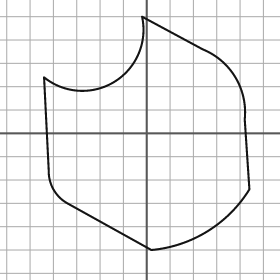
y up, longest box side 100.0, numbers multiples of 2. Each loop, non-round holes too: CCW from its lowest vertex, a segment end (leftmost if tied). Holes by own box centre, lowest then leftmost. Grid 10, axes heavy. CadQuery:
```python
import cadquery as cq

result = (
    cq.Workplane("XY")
    .moveTo(2.0, -50.0)
    .threePointArc((26.0, -42.0), (44.0, -24.0))
    .lineTo(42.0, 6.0)
    .threePointArc((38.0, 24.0), (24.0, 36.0))
    .lineTo(-2.0, 50.0)
    .threePointArc((-14.0, 22.0), (-44.0, 24.0))
    .lineTo(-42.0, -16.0)
    .threePointArc((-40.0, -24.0), (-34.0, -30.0))
    .close()
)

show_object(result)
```